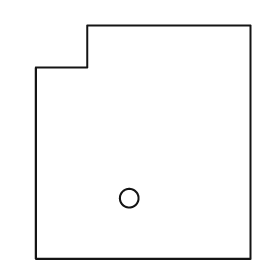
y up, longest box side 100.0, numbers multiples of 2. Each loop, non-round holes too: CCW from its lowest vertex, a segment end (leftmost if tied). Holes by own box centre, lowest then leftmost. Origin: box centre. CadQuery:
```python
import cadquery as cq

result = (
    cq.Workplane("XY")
    .moveTo(-46.0, -50.0)
    .lineTo(46.0, -50.0)
    .lineTo(46.0, 50.0)
    .lineTo(-24.0, 50.0)
    .lineTo(-24.0, 32.0)
    .lineTo(-46.0, 32.0)
    .close()
    .moveTo(-6.0, -24.0)
    .circle(4.0)
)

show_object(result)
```